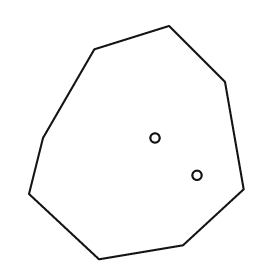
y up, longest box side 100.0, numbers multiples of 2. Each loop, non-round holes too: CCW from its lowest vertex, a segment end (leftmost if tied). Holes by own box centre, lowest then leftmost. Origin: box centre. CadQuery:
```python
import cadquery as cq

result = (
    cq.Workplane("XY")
    .moveTo(-16.0, -50.0)
    .lineTo(20.0, -44.0)
    .lineTo(46.0, -20.0)
    .lineTo(38.0, 26.0)
    .lineTo(14.0, 50.0)
    .lineTo(-18.0, 40.0)
    .lineTo(-40.0, 2.0)
    .lineTo(-46.0, -22.0)
    .close()
    .moveTo(26.0, -14.0)
    .circle(2.0)
    .moveTo(8.0, 2.0)
    .circle(2.0)
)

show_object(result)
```